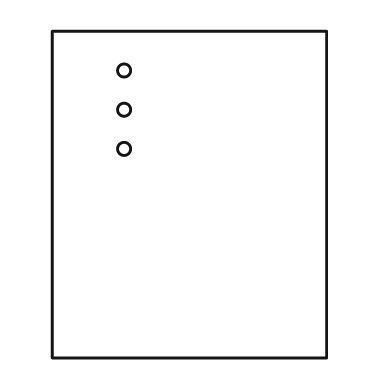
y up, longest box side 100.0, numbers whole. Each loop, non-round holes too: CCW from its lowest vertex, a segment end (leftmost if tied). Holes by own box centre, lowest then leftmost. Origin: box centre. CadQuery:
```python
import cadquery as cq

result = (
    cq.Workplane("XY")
    .moveTo(-42.0, -50.0)
    .lineTo(42.0, -50.0)
    .lineTo(42.0, 50.0)
    .lineTo(-42.0, 50.0)
    .close()
    .moveTo(-20.0, 14.0)
    .circle(2.0)
    .moveTo(-20.0, 26.0)
    .circle(2.0)
    .moveTo(-20.0, 38.0)
    .circle(2.0)
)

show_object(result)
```